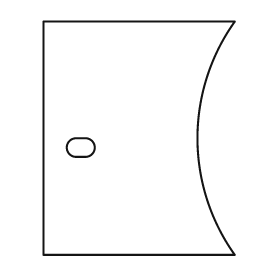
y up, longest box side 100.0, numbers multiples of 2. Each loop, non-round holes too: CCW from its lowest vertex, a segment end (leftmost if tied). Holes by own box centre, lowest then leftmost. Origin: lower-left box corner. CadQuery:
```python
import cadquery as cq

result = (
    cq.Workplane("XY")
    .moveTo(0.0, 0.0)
    .lineTo(82.0, 0.0)
    .threePointArc((66.0, 50.0), (82.0, 100.0))
    .lineTo(0.0, 100.0)
    .close()
    .moveTo(14.0, 42.0)
    .lineTo(18.0, 42.0)
    .threePointArc((22.0, 46.0), (18.0, 50.0))
    .lineTo(14.0, 50.0)
    .threePointArc((10.0, 46.0), (14.0, 42.0))
    .close()
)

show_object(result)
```